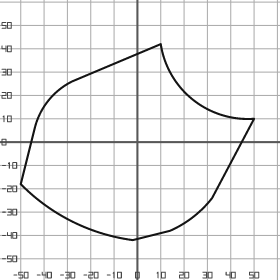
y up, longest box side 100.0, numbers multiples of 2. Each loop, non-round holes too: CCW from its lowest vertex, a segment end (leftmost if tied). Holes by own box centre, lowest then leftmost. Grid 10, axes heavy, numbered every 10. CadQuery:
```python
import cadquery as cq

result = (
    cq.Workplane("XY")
    .moveTo(-2.0, -42.0)
    .lineTo(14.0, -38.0)
    .threePointArc((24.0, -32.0), (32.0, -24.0))
    .lineTo(50.0, 10.0)
    .threePointArc((24.0, 18.0), (10.0, 42.0))
    .lineTo(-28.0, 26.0)
    .threePointArc((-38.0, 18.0), (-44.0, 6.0))
    .lineTo(-50.0, -18.0)
    .threePointArc((-28.0, -34.0), (-2.0, -42.0))
    .close()
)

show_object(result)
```